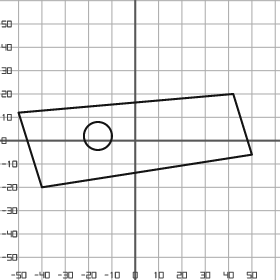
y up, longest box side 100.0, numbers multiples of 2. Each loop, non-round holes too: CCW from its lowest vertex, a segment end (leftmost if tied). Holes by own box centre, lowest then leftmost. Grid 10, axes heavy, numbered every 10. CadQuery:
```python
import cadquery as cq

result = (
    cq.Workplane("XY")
    .moveTo(-40.0, -20.0)
    .lineTo(50.0, -6.0)
    .lineTo(42.0, 20.0)
    .lineTo(-50.0, 12.0)
    .close()
    .moveTo(-16.0, 2.0)
    .circle(6.0)
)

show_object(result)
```